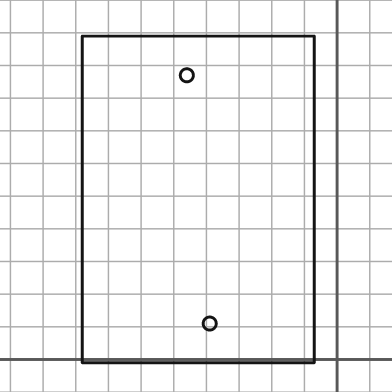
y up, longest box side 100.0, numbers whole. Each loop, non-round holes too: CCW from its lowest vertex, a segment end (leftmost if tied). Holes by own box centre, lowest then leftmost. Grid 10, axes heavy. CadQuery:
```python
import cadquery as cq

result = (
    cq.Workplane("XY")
    .moveTo(-78.0, -1.0)
    .lineTo(-7.0, -1.0)
    .lineTo(-7.0, 99.0)
    .lineTo(-78.0, 99.0)
    .close()
    .moveTo(-39.0, 11.0)
    .circle(2.0)
    .moveTo(-46.0, 87.0)
    .circle(2.0)
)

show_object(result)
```